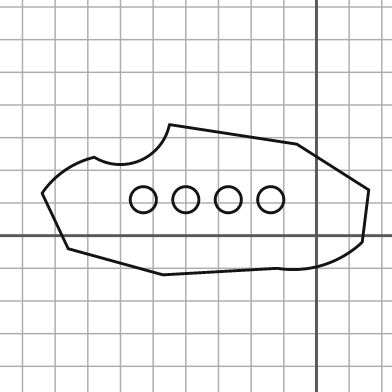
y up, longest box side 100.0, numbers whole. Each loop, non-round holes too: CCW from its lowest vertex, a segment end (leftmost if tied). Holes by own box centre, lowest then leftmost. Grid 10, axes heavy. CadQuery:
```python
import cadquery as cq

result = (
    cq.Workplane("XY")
    .moveTo(-47.0, -12.0)
    .lineTo(-12.0, -10.0)
    .threePointArc((2.0, -9.0), (14.0, -2.0))
    .lineTo(16.0, 14.0)
    .lineTo(-6.0, 28.0)
    .lineTo(-45.0, 34.0)
    .threePointArc((-54.0, 23.0), (-68.0, 24.0))
    .threePointArc((-77.0, 20.0), (-84.0, 13.0))
    .lineTo(-76.0, -4.0)
    .close()
    .moveTo(-53.0, 11.0)
    .circle(4.0)
    .moveTo(-40.0, 11.0)
    .circle(4.0)
    .moveTo(-27.0, 11.0)
    .circle(4.0)
    .moveTo(-14.0, 11.0)
    .circle(4.0)
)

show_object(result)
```